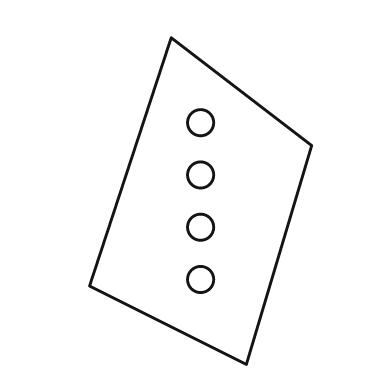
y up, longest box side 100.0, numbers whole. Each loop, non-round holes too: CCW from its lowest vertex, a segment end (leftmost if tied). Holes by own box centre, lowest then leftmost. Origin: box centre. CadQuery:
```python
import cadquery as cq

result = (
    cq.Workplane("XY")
    .moveTo(14.0, -50.0)
    .lineTo(34.0, 17.0)
    .lineTo(-9.0, 50.0)
    .lineTo(-34.0, -26.0)
    .close()
    .moveTo(0.0, -24.0)
    .circle(4.0)
    .moveTo(0.0, -8.0)
    .circle(4.0)
    .moveTo(0.0, 8.0)
    .circle(4.0)
    .moveTo(0.0, 24.0)
    .circle(4.0)
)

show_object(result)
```